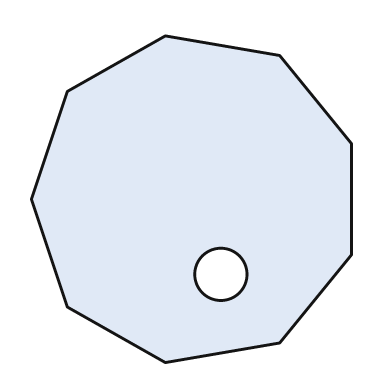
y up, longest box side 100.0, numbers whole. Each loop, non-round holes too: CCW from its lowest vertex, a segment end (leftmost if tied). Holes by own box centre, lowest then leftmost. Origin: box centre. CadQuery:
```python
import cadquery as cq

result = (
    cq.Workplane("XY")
    .moveTo(-8.0, -50.0)
    .lineTo(27.0, -44.0)
    .lineTo(49.0, -17.0)
    .lineTo(49.0, 17.0)
    .lineTo(27.0, 44.0)
    .lineTo(-8.0, 50.0)
    .lineTo(-38.0, 33.0)
    .lineTo(-49.0, 0.0)
    .lineTo(-38.0, -33.0)
    .close()
    .moveTo(9.0, -23.0)
    .circle(8.0)
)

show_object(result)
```